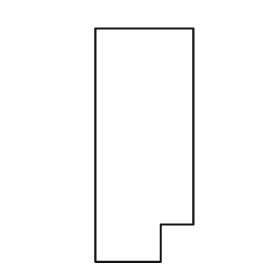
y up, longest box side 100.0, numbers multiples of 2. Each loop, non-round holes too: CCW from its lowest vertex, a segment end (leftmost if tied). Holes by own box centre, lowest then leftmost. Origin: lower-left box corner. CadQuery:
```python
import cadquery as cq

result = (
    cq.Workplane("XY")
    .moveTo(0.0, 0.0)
    .lineTo(28.0, 0.0)
    .lineTo(28.0, 16.0)
    .lineTo(42.0, 16.0)
    .lineTo(42.0, 100.0)
    .lineTo(0.0, 100.0)
    .close()
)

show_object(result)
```